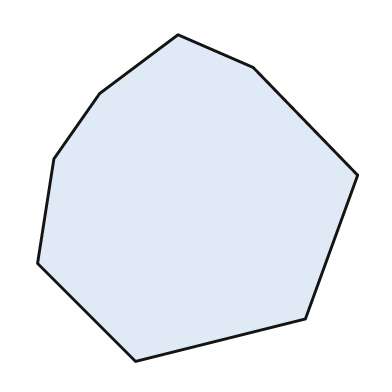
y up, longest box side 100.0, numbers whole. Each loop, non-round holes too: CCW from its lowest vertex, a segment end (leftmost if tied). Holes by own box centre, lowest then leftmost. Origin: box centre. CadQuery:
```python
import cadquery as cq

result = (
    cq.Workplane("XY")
    .moveTo(-19.0, -50.0)
    .lineTo(33.0, -37.0)
    .lineTo(49.0, 7.0)
    .lineTo(17.0, 40.0)
    .lineTo(-6.0, 50.0)
    .lineTo(-30.0, 32.0)
    .lineTo(-44.0, 12.0)
    .lineTo(-49.0, -20.0)
    .close()
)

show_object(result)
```